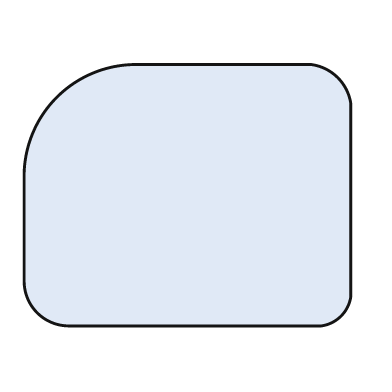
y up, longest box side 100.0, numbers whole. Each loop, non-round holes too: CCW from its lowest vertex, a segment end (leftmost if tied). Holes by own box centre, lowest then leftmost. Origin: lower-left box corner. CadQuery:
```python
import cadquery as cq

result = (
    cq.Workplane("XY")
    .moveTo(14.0, 0.0)
    .lineTo(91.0, 0.0)
    .threePointArc((97.0, 3.0), (100.0, 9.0))
    .lineTo(100.0, 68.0)
    .threePointArc((96.0, 76.0), (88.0, 80.0))
    .lineTo(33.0, 80.0)
    .threePointArc((10.0, 70.0), (0.0, 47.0))
    .lineTo(0.0, 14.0)
    .threePointArc((4.0, 4.0), (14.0, 0.0))
    .close()
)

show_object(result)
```